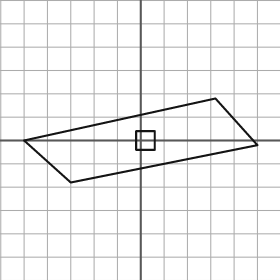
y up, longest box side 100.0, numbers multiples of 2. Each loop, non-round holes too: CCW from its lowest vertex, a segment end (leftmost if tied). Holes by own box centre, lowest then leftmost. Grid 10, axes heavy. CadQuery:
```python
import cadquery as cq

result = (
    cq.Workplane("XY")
    .moveTo(-30.0, -18.0)
    .lineTo(50.0, -2.0)
    .lineTo(32.0, 18.0)
    .lineTo(-50.0, 0.0)
    .close()
    .moveTo(-2.0, -4.0)
    .lineTo(6.0, -4.0)
    .lineTo(6.0, 4.0)
    .lineTo(-2.0, 4.0)
    .close()
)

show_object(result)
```